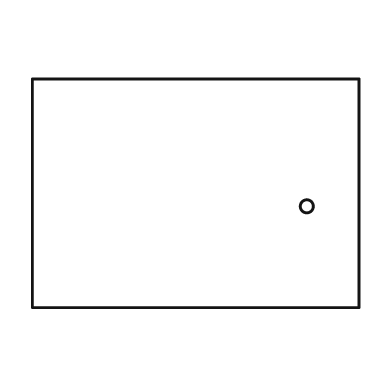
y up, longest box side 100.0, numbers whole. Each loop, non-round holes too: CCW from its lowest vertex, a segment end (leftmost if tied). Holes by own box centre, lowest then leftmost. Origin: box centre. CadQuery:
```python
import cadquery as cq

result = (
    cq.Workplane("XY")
    .moveTo(-50.0, -35.0)
    .lineTo(50.0, -35.0)
    .lineTo(50.0, 35.0)
    .lineTo(-50.0, 35.0)
    .close()
    .moveTo(34.0, -4.0)
    .circle(2.0)
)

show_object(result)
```